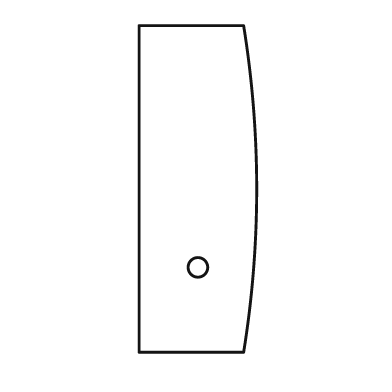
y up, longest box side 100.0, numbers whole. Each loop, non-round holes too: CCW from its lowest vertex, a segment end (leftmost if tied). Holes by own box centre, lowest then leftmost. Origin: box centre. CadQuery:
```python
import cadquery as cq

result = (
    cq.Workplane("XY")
    .moveTo(-18.0, -50.0)
    .lineTo(14.0, -50.0)
    .threePointArc((18.0, 0.0), (14.0, 50.0))
    .lineTo(-18.0, 50.0)
    .close()
    .moveTo(0.0, -24.0)
    .circle(3.0)
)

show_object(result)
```